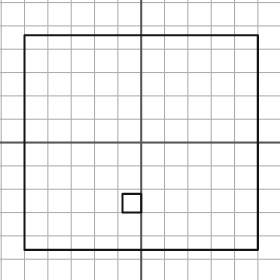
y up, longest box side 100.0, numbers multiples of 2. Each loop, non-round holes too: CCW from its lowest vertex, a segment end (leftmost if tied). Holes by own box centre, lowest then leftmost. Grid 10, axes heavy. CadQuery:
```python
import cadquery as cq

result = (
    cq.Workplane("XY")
    .moveTo(-50.0, -46.0)
    .lineTo(50.0, -46.0)
    .lineTo(50.0, 46.0)
    .lineTo(-50.0, 46.0)
    .close()
    .moveTo(-8.0, -30.0)
    .lineTo(0.0, -30.0)
    .lineTo(0.0, -22.0)
    .lineTo(-8.0, -22.0)
    .close()
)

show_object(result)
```